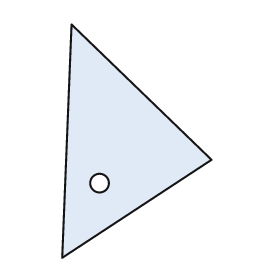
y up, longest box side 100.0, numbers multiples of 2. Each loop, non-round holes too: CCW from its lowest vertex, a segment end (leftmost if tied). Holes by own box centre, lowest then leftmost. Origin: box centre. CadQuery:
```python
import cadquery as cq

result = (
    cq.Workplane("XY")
    .moveTo(-32.0, -50.0)
    .lineTo(32.0, -8.0)
    .lineTo(-28.0, 50.0)
    .close()
    .moveTo(-16.0, -18.0)
    .circle(4.0)
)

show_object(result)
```